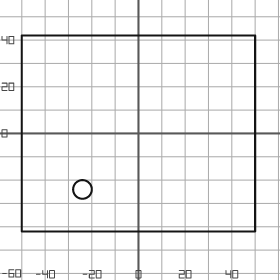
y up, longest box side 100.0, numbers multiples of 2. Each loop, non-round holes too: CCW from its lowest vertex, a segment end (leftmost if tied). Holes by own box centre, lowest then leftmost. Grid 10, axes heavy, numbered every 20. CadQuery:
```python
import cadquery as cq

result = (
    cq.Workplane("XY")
    .moveTo(-50.0, -42.0)
    .lineTo(50.0, -42.0)
    .lineTo(50.0, 42.0)
    .lineTo(-50.0, 42.0)
    .close()
    .moveTo(-24.0, -24.0)
    .circle(4.0)
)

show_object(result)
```